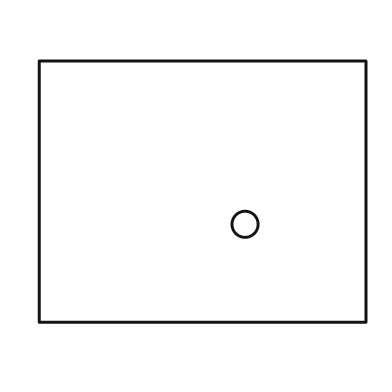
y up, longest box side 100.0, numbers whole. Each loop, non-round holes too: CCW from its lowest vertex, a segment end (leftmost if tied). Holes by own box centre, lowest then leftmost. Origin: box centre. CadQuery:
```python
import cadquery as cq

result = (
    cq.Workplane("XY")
    .moveTo(-50.0, -40.0)
    .lineTo(50.0, -40.0)
    .lineTo(50.0, 40.0)
    .lineTo(-50.0, 40.0)
    .close()
    .moveTo(13.0, -10.0)
    .circle(4.0)
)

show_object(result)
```